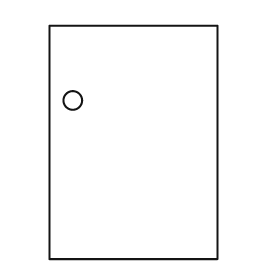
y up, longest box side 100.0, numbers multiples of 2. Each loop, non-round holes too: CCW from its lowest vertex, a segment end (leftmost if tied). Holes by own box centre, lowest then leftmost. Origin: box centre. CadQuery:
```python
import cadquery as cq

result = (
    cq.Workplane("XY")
    .moveTo(-36.0, -50.0)
    .lineTo(36.0, -50.0)
    .lineTo(36.0, 50.0)
    .lineTo(-36.0, 50.0)
    .close()
    .moveTo(-26.0, 18.0)
    .circle(4.0)
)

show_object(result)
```